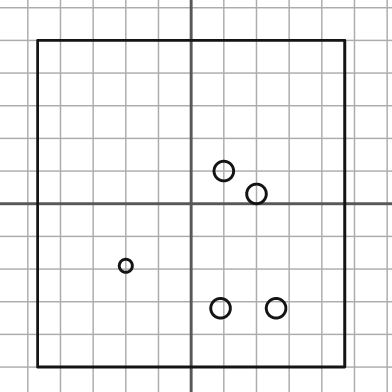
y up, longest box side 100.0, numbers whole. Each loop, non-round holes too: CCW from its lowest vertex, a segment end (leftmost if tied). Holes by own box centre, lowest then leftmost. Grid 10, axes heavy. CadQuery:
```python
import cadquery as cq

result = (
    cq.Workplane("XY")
    .moveTo(-47.0, -50.0)
    .lineTo(47.0, -50.0)
    .lineTo(47.0, 50.0)
    .lineTo(-47.0, 50.0)
    .close()
    .moveTo(9.0, -32.0)
    .circle(3.0)
    .moveTo(26.0, -32.0)
    .circle(3.0)
    .moveTo(-20.0, -19.0)
    .circle(2.0)
    .moveTo(20.0, 3.0)
    .circle(3.0)
    .moveTo(10.0, 10.0)
    .circle(3.0)
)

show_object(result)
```